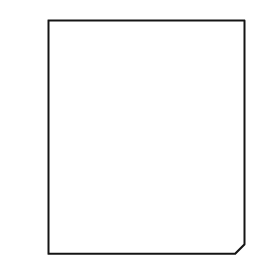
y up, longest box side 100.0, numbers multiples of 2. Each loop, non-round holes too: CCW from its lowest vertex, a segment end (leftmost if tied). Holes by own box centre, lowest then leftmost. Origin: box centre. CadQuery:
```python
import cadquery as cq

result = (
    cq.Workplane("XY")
    .moveTo(-42.0, -50.0)
    .lineTo(38.0, -50.0)
    .lineTo(42.0, -46.0)
    .lineTo(42.0, 50.0)
    .lineTo(-42.0, 50.0)
    .close()
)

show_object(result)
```